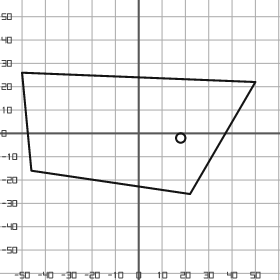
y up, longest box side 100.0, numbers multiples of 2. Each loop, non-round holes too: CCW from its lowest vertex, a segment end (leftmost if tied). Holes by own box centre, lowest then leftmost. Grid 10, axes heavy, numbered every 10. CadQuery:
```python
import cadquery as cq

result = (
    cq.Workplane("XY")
    .moveTo(22.0, -26.0)
    .lineTo(50.0, 22.0)
    .lineTo(-50.0, 26.0)
    .lineTo(-46.0, -16.0)
    .close()
    .moveTo(18.0, -2.0)
    .circle(2.0)
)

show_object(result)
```